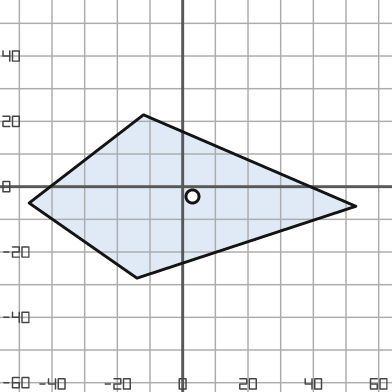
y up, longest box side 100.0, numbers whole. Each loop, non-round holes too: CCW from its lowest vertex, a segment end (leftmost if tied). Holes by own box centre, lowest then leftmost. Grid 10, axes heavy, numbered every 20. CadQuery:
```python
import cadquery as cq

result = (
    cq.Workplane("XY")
    .moveTo(-14.0, -28.0)
    .lineTo(53.0, -6.0)
    .lineTo(-12.0, 22.0)
    .lineTo(-47.0, -5.0)
    .close()
    .moveTo(3.0, -3.0)
    .circle(2.0)
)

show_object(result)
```